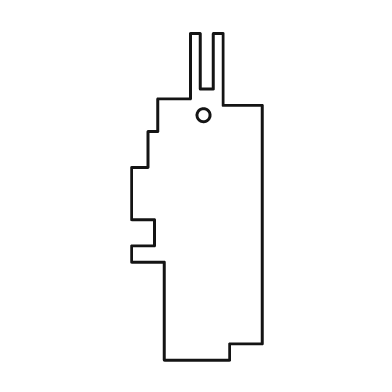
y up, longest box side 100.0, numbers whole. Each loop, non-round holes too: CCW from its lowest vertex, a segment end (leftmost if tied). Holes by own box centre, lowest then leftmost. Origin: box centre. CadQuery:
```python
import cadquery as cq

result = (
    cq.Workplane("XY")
    .moveTo(-10.0, -50.0)
    .lineTo(10.0, -50.0)
    .lineTo(10.0, -45.0)
    .lineTo(20.0, -45.0)
    .lineTo(20.0, 28.0)
    .lineTo(8.0, 28.0)
    .lineTo(8.0, 50.0)
    .lineTo(5.0, 50.0)
    .lineTo(5.0, 33.0)
    .lineTo(1.0, 33.0)
    .lineTo(1.0, 50.0)
    .lineTo(-2.0, 50.0)
    .lineTo(-2.0, 30.0)
    .lineTo(-12.0, 30.0)
    .lineTo(-12.0, 20.0)
    .lineTo(-15.0, 20.0)
    .lineTo(-15.0, 9.0)
    .lineTo(-20.0, 9.0)
    .lineTo(-20.0, -7.0)
    .lineTo(-13.0, -7.0)
    .lineTo(-13.0, -15.0)
    .lineTo(-20.0, -15.0)
    .lineTo(-20.0, -20.0)
    .lineTo(-10.0, -20.0)
    .close()
    .moveTo(2.0, 25.0)
    .circle(2.0)
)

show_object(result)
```